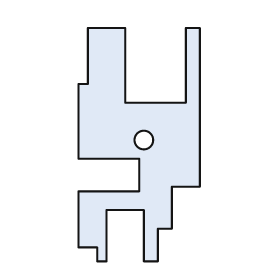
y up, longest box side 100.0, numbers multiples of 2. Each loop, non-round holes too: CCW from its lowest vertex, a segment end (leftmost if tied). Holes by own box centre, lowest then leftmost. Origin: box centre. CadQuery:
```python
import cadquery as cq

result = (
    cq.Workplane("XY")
    .moveTo(-18.0, -50.0)
    .lineTo(-14.0, -50.0)
    .lineTo(-14.0, -28.0)
    .lineTo(2.0, -28.0)
    .lineTo(2.0, -50.0)
    .lineTo(8.0, -50.0)
    .lineTo(8.0, -36.0)
    .lineTo(14.0, -36.0)
    .lineTo(14.0, -18.0)
    .lineTo(26.0, -18.0)
    .lineTo(26.0, 50.0)
    .lineTo(20.0, 50.0)
    .lineTo(20.0, 18.0)
    .lineTo(-6.0, 18.0)
    .lineTo(-6.0, 50.0)
    .lineTo(-22.0, 50.0)
    .lineTo(-22.0, 26.0)
    .lineTo(-26.0, 26.0)
    .lineTo(-26.0, -6.0)
    .lineTo(0.0, -6.0)
    .lineTo(0.0, -20.0)
    .lineTo(-26.0, -20.0)
    .lineTo(-26.0, -44.0)
    .lineTo(-18.0, -44.0)
    .close()
    .moveTo(2.0, 2.0)
    .circle(4.0)
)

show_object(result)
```